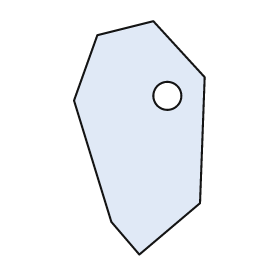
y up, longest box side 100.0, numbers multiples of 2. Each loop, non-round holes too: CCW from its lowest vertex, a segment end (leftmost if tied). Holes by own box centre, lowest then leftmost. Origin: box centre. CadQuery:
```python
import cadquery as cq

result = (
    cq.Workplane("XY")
    .moveTo(0.0, -50.0)
    .lineTo(26.0, -28.0)
    .lineTo(28.0, 26.0)
    .lineTo(6.0, 50.0)
    .lineTo(-18.0, 44.0)
    .lineTo(-28.0, 16.0)
    .lineTo(-12.0, -36.0)
    .close()
    .moveTo(12.0, 18.0)
    .circle(6.0)
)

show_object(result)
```